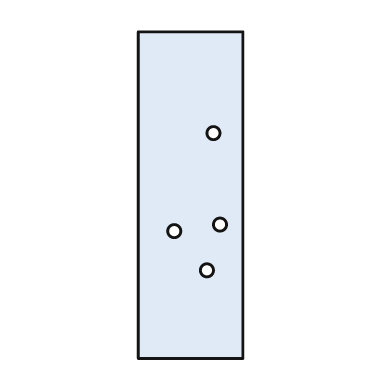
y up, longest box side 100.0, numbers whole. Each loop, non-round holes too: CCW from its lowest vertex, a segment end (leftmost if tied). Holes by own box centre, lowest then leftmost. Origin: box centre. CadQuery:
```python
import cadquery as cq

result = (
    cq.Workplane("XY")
    .moveTo(-16.0, -50.0)
    .lineTo(16.0, -50.0)
    .lineTo(16.0, 50.0)
    .lineTo(-16.0, 50.0)
    .close()
    .moveTo(5.0, -23.0)
    .circle(2.0)
    .moveTo(-5.0, -11.0)
    .circle(2.0)
    .moveTo(9.0, -9.0)
    .circle(2.0)
    .moveTo(7.0, 19.0)
    .circle(2.0)
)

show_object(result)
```